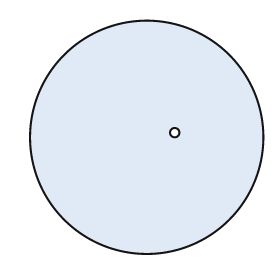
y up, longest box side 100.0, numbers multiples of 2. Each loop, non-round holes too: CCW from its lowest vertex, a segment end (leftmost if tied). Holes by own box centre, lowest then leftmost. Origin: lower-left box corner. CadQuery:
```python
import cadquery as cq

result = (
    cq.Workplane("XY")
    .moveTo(50.0, 50.0)
    .circle(50.0)
    .moveTo(62.0, 52.0)
    .circle(2.0)
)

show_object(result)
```